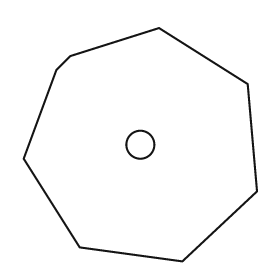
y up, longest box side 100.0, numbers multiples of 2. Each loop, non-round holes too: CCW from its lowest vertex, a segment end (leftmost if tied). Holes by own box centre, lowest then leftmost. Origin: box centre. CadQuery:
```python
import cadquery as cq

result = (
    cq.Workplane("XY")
    .moveTo(18.0, -50.0)
    .lineTo(50.0, -20.0)
    .lineTo(46.0, 26.0)
    .lineTo(8.0, 50.0)
    .lineTo(-30.0, 38.0)
    .lineTo(-36.0, 32.0)
    .lineTo(-50.0, -6.0)
    .lineTo(-26.0, -44.0)
    .close()
    .moveTo(0.0, 0.0)
    .circle(6.0)
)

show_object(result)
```